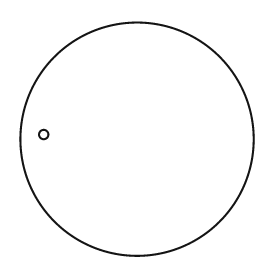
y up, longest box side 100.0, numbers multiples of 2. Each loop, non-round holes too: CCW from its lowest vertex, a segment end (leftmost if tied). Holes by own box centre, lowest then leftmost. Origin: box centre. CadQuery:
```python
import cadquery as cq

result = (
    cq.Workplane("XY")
    .moveTo(0.0, 0.0)
    .circle(50.0)
    .moveTo(-40.0, 2.0)
    .circle(2.0)
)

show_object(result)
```